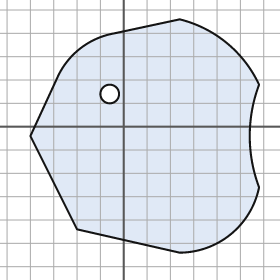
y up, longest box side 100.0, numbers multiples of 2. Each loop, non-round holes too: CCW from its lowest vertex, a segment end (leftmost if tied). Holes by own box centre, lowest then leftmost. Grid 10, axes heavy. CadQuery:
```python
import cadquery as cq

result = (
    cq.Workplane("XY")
    .moveTo(24.0, -54.0)
    .threePointArc((46.0, -46.0), (58.0, -26.0))
    .threePointArc((54.0, -4.0), (58.0, 18.0))
    .threePointArc((44.0, 36.0), (24.0, 46.0))
    .lineTo(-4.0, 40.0)
    .threePointArc((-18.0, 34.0), (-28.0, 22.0))
    .lineTo(-40.0, -4.0)
    .lineTo(-20.0, -44.0)
    .close()
    .moveTo(-6.0, 14.0)
    .circle(4.0)
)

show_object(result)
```